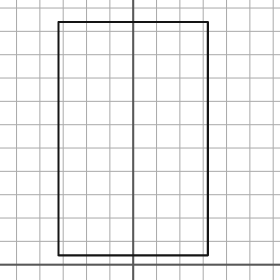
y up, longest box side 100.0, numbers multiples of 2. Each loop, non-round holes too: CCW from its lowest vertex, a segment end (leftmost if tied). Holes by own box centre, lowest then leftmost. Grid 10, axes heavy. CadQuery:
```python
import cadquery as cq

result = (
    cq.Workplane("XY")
    .moveTo(-32.0, 4.0)
    .lineTo(32.0, 4.0)
    .lineTo(32.0, 104.0)
    .lineTo(-32.0, 104.0)
    .close()
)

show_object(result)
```